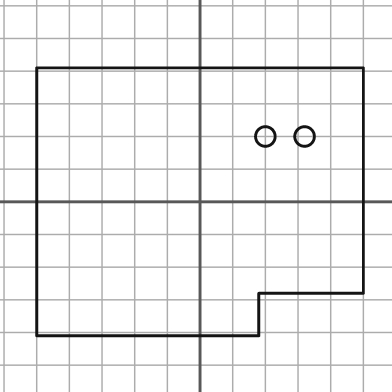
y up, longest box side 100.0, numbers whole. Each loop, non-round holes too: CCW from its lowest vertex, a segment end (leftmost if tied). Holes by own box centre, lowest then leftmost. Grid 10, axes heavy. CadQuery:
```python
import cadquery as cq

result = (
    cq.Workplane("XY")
    .moveTo(-50.0, -41.0)
    .lineTo(18.0, -41.0)
    .lineTo(18.0, -28.0)
    .lineTo(50.0, -28.0)
    .lineTo(50.0, 41.0)
    .lineTo(-50.0, 41.0)
    .close()
    .moveTo(20.0, 20.0)
    .circle(3.0)
    .moveTo(32.0, 20.0)
    .circle(3.0)
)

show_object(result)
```